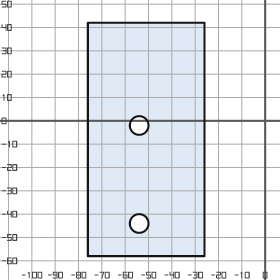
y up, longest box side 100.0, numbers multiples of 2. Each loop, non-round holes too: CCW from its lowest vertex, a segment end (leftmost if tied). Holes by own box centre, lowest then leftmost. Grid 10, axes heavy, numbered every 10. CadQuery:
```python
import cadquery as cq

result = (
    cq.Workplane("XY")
    .moveTo(-76.0, -58.0)
    .lineTo(-26.0, -58.0)
    .lineTo(-26.0, 42.0)
    .lineTo(-76.0, 42.0)
    .close()
    .moveTo(-54.0, -44.0)
    .circle(4.0)
    .moveTo(-54.0, -2.0)
    .circle(4.0)
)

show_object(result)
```